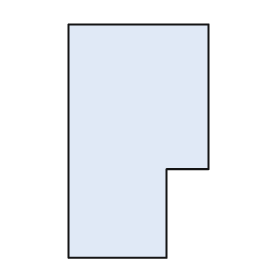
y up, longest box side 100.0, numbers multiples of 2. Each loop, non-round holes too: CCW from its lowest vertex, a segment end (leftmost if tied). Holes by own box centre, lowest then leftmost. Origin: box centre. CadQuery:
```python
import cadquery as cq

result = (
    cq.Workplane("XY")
    .moveTo(-30.0, -50.0)
    .lineTo(12.0, -50.0)
    .lineTo(12.0, -12.0)
    .lineTo(30.0, -12.0)
    .lineTo(30.0, 50.0)
    .lineTo(-30.0, 50.0)
    .close()
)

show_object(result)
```